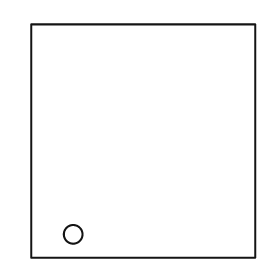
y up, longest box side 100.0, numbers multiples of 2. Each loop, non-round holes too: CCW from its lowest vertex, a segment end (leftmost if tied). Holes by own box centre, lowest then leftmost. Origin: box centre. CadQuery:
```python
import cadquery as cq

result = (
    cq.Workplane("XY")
    .moveTo(-48.0, -50.0)
    .lineTo(48.0, -50.0)
    .lineTo(48.0, 50.0)
    .lineTo(-48.0, 50.0)
    .close()
    .moveTo(-30.0, -40.0)
    .circle(4.0)
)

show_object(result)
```